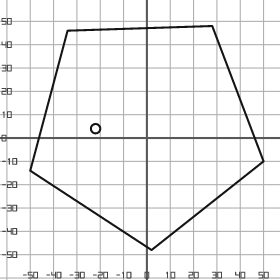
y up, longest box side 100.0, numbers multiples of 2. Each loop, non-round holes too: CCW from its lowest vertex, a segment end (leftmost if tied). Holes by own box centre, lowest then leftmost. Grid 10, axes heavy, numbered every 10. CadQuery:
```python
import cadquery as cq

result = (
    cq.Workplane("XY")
    .moveTo(2.0, -48.0)
    .lineTo(50.0, -10.0)
    .lineTo(28.0, 48.0)
    .lineTo(-34.0, 46.0)
    .lineTo(-50.0, -14.0)
    .close()
    .moveTo(-22.0, 4.0)
    .circle(2.0)
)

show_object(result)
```